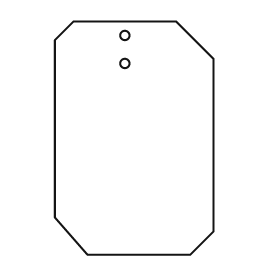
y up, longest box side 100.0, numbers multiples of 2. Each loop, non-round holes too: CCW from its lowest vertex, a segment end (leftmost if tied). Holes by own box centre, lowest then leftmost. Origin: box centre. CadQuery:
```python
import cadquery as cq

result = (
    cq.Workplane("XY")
    .moveTo(-20.0, -50.0)
    .lineTo(24.0, -50.0)
    .lineTo(34.0, -40.0)
    .lineTo(34.0, 34.0)
    .lineTo(18.0, 50.0)
    .lineTo(-26.0, 50.0)
    .lineTo(-34.0, 42.0)
    .lineTo(-34.0, -34.0)
    .close()
    .moveTo(-4.0, 32.0)
    .circle(2.0)
    .moveTo(-4.0, 44.0)
    .circle(2.0)
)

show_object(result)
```